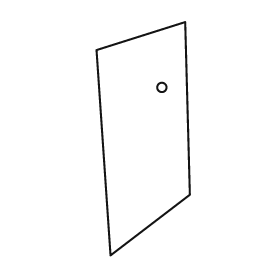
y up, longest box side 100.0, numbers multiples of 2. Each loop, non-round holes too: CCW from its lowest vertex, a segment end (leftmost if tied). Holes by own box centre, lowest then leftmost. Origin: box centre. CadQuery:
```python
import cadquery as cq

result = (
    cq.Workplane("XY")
    .moveTo(-14.0, -50.0)
    .lineTo(20.0, -24.0)
    .lineTo(18.0, 50.0)
    .lineTo(-20.0, 38.0)
    .close()
    .moveTo(8.0, 22.0)
    .circle(2.0)
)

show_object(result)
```